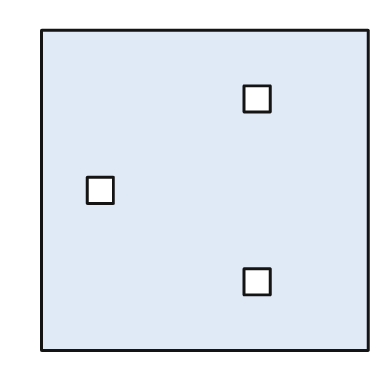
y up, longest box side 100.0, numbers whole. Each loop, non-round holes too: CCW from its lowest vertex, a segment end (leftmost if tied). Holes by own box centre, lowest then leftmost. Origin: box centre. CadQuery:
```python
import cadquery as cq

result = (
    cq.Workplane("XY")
    .moveTo(-50.0, -49.0)
    .lineTo(50.0, -49.0)
    .lineTo(50.0, 49.0)
    .lineTo(-50.0, 49.0)
    .close()
    .moveTo(12.0, -32.0)
    .lineTo(20.0, -32.0)
    .lineTo(20.0, -24.0)
    .lineTo(12.0, -24.0)
    .close()
    .moveTo(-36.0, -4.0)
    .lineTo(-28.0, -4.0)
    .lineTo(-28.0, 4.0)
    .lineTo(-36.0, 4.0)
    .close()
    .moveTo(12.0, 24.0)
    .lineTo(20.0, 24.0)
    .lineTo(20.0, 32.0)
    .lineTo(12.0, 32.0)
    .close()
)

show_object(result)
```